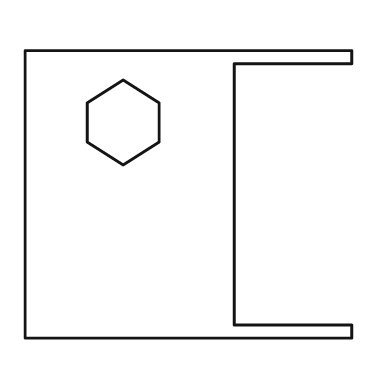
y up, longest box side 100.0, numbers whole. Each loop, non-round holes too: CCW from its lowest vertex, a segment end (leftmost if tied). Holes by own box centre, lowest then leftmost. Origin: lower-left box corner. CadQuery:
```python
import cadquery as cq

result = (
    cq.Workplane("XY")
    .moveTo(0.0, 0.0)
    .lineTo(100.0, 0.0)
    .lineTo(100.0, 4.0)
    .lineTo(64.0, 4.0)
    .lineTo(64.0, 84.0)
    .lineTo(100.0, 84.0)
    .lineTo(100.0, 88.0)
    .lineTo(0.0, 88.0)
    .close()
    .moveTo(30.0, 53.0)
    .lineTo(41.0, 60.0)
    .lineTo(41.0, 72.0)
    .lineTo(30.0, 79.0)
    .lineTo(19.0, 72.0)
    .lineTo(19.0, 60.0)
    .close()
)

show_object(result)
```